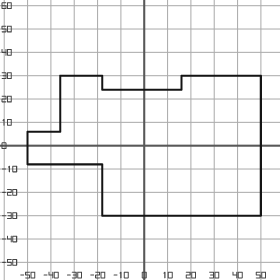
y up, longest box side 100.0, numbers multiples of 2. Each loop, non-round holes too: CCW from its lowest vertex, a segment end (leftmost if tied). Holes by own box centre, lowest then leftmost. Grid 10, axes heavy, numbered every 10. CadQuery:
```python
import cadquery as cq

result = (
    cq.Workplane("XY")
    .moveTo(-18.0, -30.0)
    .lineTo(50.0, -30.0)
    .lineTo(50.0, 30.0)
    .lineTo(16.0, 30.0)
    .lineTo(16.0, 24.0)
    .lineTo(-18.0, 24.0)
    .lineTo(-18.0, 30.0)
    .lineTo(-36.0, 30.0)
    .lineTo(-36.0, 6.0)
    .lineTo(-50.0, 6.0)
    .lineTo(-50.0, -8.0)
    .lineTo(-18.0, -8.0)
    .close()
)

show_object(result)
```